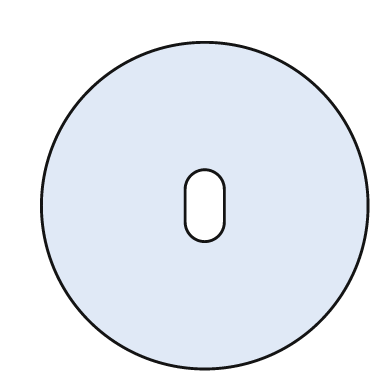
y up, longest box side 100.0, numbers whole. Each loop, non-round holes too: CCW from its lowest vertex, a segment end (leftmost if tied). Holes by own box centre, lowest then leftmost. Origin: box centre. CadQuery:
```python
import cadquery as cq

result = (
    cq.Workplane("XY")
    .moveTo(0.0, 0.0)
    .circle(50.0)
    .moveTo(-6.0, -5.0)
    .threePointArc((0.0, -11.0), (6.0, -5.0))
    .lineTo(6.0, 5.0)
    .threePointArc((0.0, 11.0), (-6.0, 5.0))
    .close()
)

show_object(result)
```